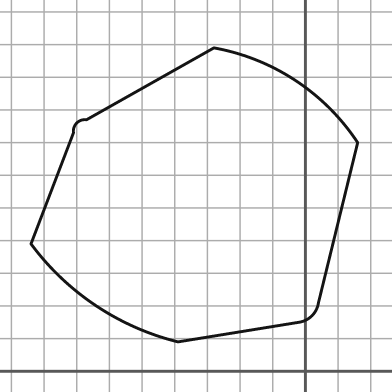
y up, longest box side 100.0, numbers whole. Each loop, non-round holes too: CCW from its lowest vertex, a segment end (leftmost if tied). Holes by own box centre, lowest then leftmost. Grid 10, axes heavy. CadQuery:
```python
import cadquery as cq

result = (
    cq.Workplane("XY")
    .moveTo(-39.0, 9.0)
    .lineTo(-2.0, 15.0)
    .threePointArc((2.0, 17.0), (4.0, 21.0))
    .lineTo(16.0, 70.0)
    .threePointArc((-3.0, 89.0), (-28.0, 99.0))
    .lineTo(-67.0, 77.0)
    .threePointArc((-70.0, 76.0), (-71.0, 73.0))
    .lineTo(-84.0, 39.0)
    .threePointArc((-64.0, 20.0), (-39.0, 9.0))
    .close()
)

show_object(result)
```